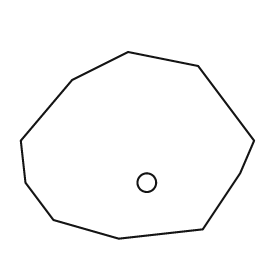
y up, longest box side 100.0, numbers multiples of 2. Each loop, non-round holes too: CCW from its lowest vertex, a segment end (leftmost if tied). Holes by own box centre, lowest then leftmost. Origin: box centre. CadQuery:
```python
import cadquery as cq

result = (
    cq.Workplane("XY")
    .moveTo(-8.0, -40.0)
    .lineTo(28.0, -36.0)
    .lineTo(44.0, -12.0)
    .lineTo(50.0, 2.0)
    .lineTo(26.0, 34.0)
    .lineTo(-4.0, 40.0)
    .lineTo(-28.0, 28.0)
    .lineTo(-50.0, 2.0)
    .lineTo(-48.0, -16.0)
    .lineTo(-36.0, -32.0)
    .close()
    .moveTo(4.0, -16.0)
    .circle(4.0)
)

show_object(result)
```